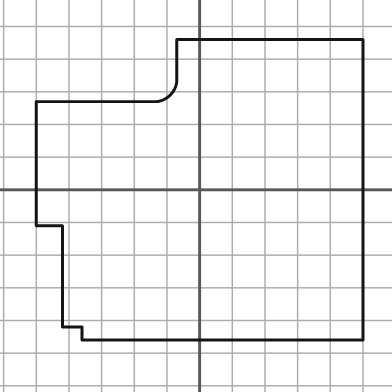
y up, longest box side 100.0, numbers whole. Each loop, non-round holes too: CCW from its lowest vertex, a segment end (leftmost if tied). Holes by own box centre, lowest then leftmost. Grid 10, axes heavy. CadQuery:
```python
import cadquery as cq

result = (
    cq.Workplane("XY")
    .moveTo(-36.0, -46.0)
    .lineTo(50.0, -46.0)
    .lineTo(50.0, 46.0)
    .lineTo(-7.0, 46.0)
    .lineTo(-7.0, 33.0)
    .threePointArc((-9.0, 29.0), (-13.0, 27.0))
    .lineTo(-50.0, 27.0)
    .lineTo(-50.0, -11.0)
    .lineTo(-42.0, -11.0)
    .lineTo(-42.0, -42.0)
    .lineTo(-36.0, -42.0)
    .close()
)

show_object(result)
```